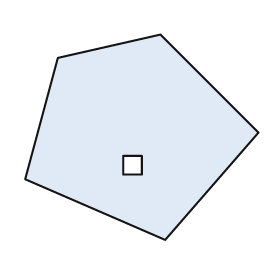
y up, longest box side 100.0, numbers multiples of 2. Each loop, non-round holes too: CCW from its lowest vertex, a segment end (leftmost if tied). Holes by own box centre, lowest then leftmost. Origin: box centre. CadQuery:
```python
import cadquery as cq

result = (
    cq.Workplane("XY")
    .moveTo(10.0, -44.0)
    .lineTo(50.0, 2.0)
    .lineTo(8.0, 44.0)
    .lineTo(-36.0, 34.0)
    .lineTo(-50.0, -18.0)
    .close()
    .moveTo(-8.0, -16.0)
    .lineTo(0.0, -16.0)
    .lineTo(0.0, -8.0)
    .lineTo(-8.0, -8.0)
    .close()
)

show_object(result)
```